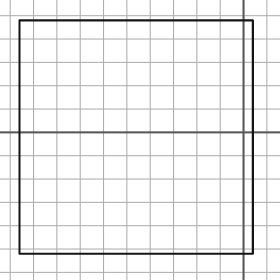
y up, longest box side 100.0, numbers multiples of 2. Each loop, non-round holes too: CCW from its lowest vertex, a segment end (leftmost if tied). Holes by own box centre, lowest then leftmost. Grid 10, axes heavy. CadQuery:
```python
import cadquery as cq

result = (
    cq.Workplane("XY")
    .moveTo(-96.0, -52.0)
    .lineTo(4.0, -52.0)
    .lineTo(4.0, 48.0)
    .lineTo(-96.0, 48.0)
    .close()
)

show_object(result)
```